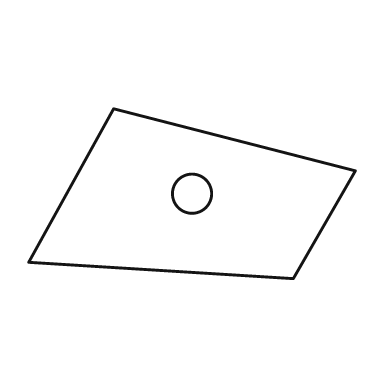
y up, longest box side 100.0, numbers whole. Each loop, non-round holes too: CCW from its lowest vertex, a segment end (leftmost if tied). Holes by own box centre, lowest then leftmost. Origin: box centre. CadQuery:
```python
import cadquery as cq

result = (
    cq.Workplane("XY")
    .moveTo(31.0, -26.0)
    .lineTo(50.0, 7.0)
    .lineTo(-24.0, 26.0)
    .lineTo(-50.0, -21.0)
    .close()
    .moveTo(0.0, 0.0)
    .circle(6.0)
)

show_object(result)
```